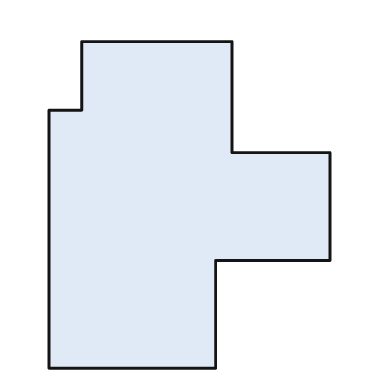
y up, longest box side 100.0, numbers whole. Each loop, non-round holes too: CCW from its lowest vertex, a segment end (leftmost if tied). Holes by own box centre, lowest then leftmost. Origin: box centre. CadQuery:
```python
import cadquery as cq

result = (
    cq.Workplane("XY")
    .moveTo(-43.0, -50.0)
    .lineTo(8.0, -50.0)
    .lineTo(8.0, -17.0)
    .lineTo(43.0, -17.0)
    .lineTo(43.0, 16.0)
    .lineTo(13.0, 16.0)
    .lineTo(13.0, 50.0)
    .lineTo(-33.0, 50.0)
    .lineTo(-33.0, 29.0)
    .lineTo(-43.0, 29.0)
    .close()
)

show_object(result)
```